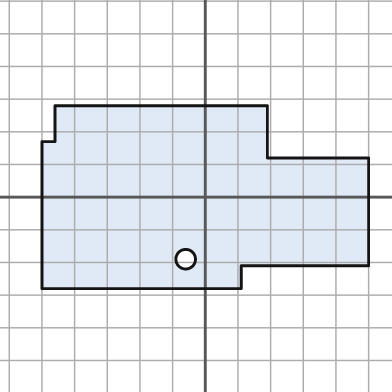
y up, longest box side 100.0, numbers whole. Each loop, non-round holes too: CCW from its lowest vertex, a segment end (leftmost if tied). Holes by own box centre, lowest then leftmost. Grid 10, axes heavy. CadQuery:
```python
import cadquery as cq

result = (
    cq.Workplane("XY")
    .moveTo(-50.0, -28.0)
    .lineTo(11.0, -28.0)
    .lineTo(11.0, -21.0)
    .lineTo(50.0, -21.0)
    .lineTo(50.0, 12.0)
    .lineTo(19.0, 12.0)
    .lineTo(19.0, 28.0)
    .lineTo(-46.0, 28.0)
    .lineTo(-46.0, 17.0)
    .lineTo(-50.0, 17.0)
    .close()
    .moveTo(-6.0, -19.0)
    .circle(3.0)
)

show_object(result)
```